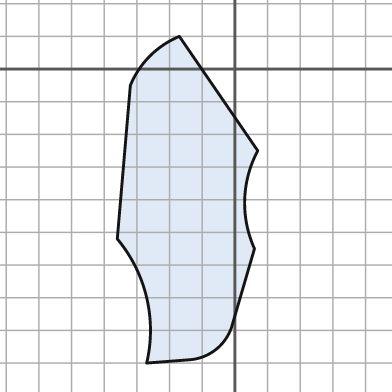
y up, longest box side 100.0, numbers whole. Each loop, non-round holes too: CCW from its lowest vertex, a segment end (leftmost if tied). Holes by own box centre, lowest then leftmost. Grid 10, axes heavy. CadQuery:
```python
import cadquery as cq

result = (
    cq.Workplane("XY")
    .moveTo(-27.0, -90.0)
    .lineTo(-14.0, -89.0)
    .threePointArc((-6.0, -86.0), (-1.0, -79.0))
    .lineTo(6.0, -55.0)
    .threePointArc((3.0, -40.0), (7.0, -25.0))
    .lineTo(-17.0, 10.0)
    .threePointArc((-26.0, 4.0), (-32.0, -5.0))
    .lineTo(-36.0, -52.0)
    .threePointArc((-27.0, -70.0), (-27.0, -90.0))
    .close()
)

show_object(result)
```